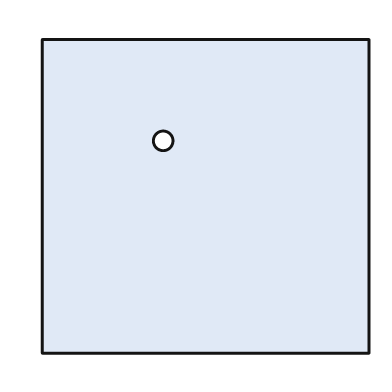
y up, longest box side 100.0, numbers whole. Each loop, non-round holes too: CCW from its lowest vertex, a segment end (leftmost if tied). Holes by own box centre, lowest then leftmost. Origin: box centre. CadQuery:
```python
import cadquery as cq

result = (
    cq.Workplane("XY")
    .moveTo(-50.0, -48.0)
    .lineTo(50.0, -48.0)
    .lineTo(50.0, 48.0)
    .lineTo(-50.0, 48.0)
    .close()
    .moveTo(-13.0, 17.0)
    .circle(3.0)
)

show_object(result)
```